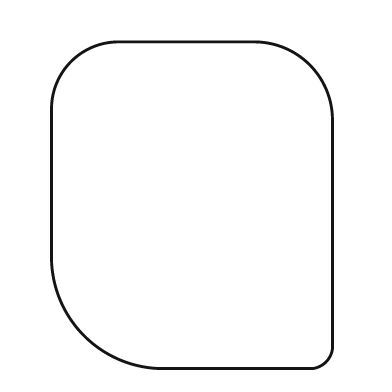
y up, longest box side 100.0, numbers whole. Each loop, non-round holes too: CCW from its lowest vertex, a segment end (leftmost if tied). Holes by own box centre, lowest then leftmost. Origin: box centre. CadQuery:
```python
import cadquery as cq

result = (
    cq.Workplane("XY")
    .moveTo(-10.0, -50.0)
    .lineTo(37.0, -50.0)
    .threePointArc((41.0, -48.0), (43.0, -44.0))
    .lineTo(43.0, 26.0)
    .threePointArc((36.0, 43.0), (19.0, 50.0))
    .lineTo(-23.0, 50.0)
    .threePointArc((-37.0, 44.0), (-43.0, 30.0))
    .lineTo(-43.0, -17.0)
    .threePointArc((-33.0, -40.0), (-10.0, -50.0))
    .close()
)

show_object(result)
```